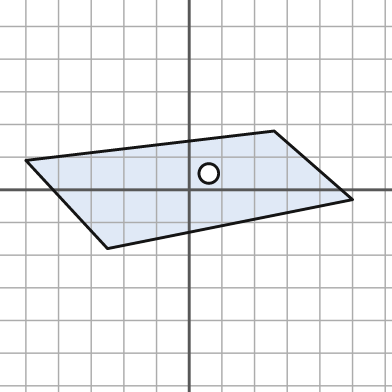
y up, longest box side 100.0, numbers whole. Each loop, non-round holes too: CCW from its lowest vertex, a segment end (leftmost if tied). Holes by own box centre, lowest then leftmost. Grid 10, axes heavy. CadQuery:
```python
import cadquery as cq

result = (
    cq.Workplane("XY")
    .moveTo(-25.0, -18.0)
    .lineTo(50.0, -3.0)
    .lineTo(26.0, 18.0)
    .lineTo(-50.0, 9.0)
    .close()
    .moveTo(6.0, 5.0)
    .circle(3.0)
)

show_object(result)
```